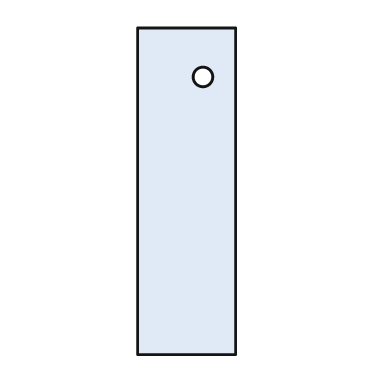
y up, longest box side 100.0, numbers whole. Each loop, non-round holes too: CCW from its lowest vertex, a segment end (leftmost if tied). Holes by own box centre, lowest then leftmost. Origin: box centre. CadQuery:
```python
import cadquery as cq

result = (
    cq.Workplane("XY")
    .moveTo(-15.0, -50.0)
    .lineTo(15.0, -50.0)
    .lineTo(15.0, 50.0)
    .lineTo(-15.0, 50.0)
    .close()
    .moveTo(5.0, 35.0)
    .circle(3.0)
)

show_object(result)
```